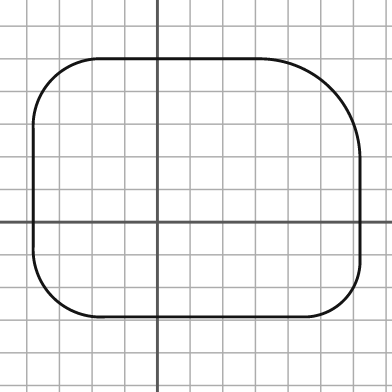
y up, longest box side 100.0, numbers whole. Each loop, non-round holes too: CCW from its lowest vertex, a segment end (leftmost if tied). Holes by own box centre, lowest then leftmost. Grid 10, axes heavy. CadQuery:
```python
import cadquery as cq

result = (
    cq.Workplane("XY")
    .moveTo(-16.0, -29.0)
    .lineTo(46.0, -29.0)
    .threePointArc((57.0, -24.0), (62.0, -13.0))
    .lineTo(62.0, 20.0)
    .threePointArc((53.0, 41.0), (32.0, 50.0))
    .lineTo(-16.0, 50.0)
    .threePointArc((-32.0, 44.0), (-38.0, 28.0))
    .lineTo(-38.0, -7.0)
    .threePointArc((-32.0, -23.0), (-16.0, -29.0))
    .close()
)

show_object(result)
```